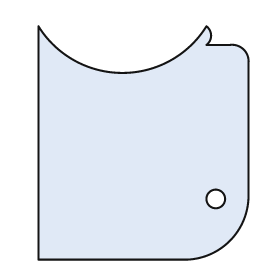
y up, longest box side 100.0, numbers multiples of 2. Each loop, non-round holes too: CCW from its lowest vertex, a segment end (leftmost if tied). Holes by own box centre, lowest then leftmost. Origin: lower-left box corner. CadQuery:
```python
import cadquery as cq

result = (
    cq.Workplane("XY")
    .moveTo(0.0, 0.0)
    .lineTo(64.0, 0.0)
    .threePointArc((82.0, 8.0), (90.0, 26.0))
    .lineTo(90.0, 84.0)
    .threePointArc((88.0, 90.0), (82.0, 92.0))
    .lineTo(72.0, 92.0)
    .threePointArc((74.0, 96.0), (72.0, 100.0))
    .threePointArc((36.0, 80.0), (0.0, 100.0))
    .close()
    .moveTo(76.0, 26.0)
    .circle(4.0)
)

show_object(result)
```